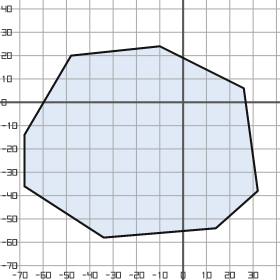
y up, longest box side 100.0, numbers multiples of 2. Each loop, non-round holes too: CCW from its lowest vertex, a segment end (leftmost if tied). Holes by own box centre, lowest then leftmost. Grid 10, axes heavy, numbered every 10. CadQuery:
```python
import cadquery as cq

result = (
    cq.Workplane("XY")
    .moveTo(-34.0, -58.0)
    .lineTo(14.0, -54.0)
    .lineTo(32.0, -38.0)
    .lineTo(26.0, 6.0)
    .lineTo(-10.0, 24.0)
    .lineTo(-48.0, 20.0)
    .lineTo(-68.0, -14.0)
    .lineTo(-68.0, -36.0)
    .close()
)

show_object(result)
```